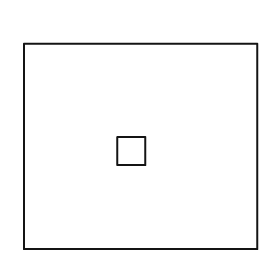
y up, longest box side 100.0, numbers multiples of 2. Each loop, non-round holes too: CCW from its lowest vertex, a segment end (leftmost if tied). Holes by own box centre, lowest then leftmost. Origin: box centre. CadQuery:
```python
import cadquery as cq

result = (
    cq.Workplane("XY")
    .moveTo(-50.0, -44.0)
    .lineTo(50.0, -44.0)
    .lineTo(50.0, 44.0)
    .lineTo(-50.0, 44.0)
    .close()
    .moveTo(-10.0, -8.0)
    .lineTo(2.0, -8.0)
    .lineTo(2.0, 4.0)
    .lineTo(-10.0, 4.0)
    .close()
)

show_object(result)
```